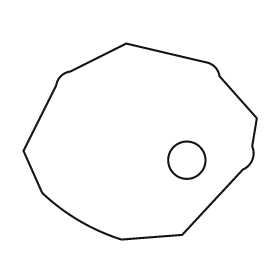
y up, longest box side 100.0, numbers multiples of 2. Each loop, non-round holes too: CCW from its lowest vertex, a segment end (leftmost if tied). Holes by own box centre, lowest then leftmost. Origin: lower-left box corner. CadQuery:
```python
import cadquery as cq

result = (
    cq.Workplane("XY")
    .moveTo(42.0, 0.0)
    .lineTo(68.0, 2.0)
    .lineTo(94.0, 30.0)
    .threePointArc((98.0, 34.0), (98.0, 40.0))
    .lineTo(100.0, 52.0)
    .lineTo(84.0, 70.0)
    .threePointArc((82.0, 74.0), (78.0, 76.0))
    .lineTo(44.0, 84.0)
    .lineTo(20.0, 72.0)
    .threePointArc((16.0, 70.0), (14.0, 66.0))
    .lineTo(0.0, 38.0)
    .lineTo(8.0, 20.0)
    .threePointArc((24.0, 8.0), (42.0, 0.0))
    .close()
    .moveTo(70.0, 34.0)
    .circle(8.0)
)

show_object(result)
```